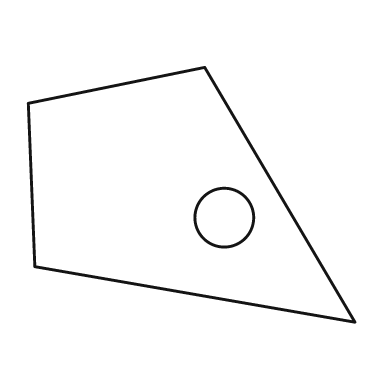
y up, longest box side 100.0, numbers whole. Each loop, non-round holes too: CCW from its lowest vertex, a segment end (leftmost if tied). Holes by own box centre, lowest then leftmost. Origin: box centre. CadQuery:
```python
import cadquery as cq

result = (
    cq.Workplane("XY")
    .moveTo(50.0, -39.0)
    .lineTo(4.0, 39.0)
    .lineTo(-50.0, 28.0)
    .lineTo(-48.0, -22.0)
    .close()
    .moveTo(10.0, -7.0)
    .circle(9.0)
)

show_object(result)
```